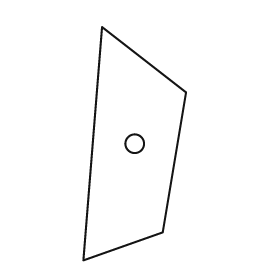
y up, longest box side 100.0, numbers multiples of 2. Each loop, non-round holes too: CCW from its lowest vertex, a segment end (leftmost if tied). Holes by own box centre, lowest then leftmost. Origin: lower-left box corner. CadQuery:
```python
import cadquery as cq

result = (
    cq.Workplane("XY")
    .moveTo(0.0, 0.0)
    .lineTo(34.0, 12.0)
    .lineTo(44.0, 72.0)
    .lineTo(8.0, 100.0)
    .close()
    .moveTo(22.0, 50.0)
    .circle(4.0)
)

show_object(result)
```